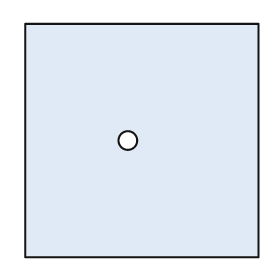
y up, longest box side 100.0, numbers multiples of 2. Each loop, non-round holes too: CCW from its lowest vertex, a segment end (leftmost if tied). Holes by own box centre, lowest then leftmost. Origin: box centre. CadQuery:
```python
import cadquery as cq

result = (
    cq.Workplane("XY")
    .moveTo(-50.0, -50.0)
    .lineTo(50.0, -50.0)
    .lineTo(50.0, 50.0)
    .lineTo(-50.0, 50.0)
    .close()
    .moveTo(-6.0, 0.0)
    .circle(4.0)
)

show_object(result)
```